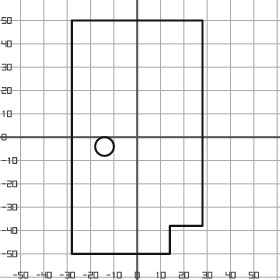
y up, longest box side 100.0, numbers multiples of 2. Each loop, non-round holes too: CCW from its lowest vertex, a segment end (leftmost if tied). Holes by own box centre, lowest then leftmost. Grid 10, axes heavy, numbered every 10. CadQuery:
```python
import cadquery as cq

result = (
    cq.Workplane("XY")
    .moveTo(-28.0, -50.0)
    .lineTo(14.0, -50.0)
    .lineTo(14.0, -38.0)
    .lineTo(28.0, -38.0)
    .lineTo(28.0, 50.0)
    .lineTo(-28.0, 50.0)
    .close()
    .moveTo(-14.0, -4.0)
    .circle(4.0)
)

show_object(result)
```